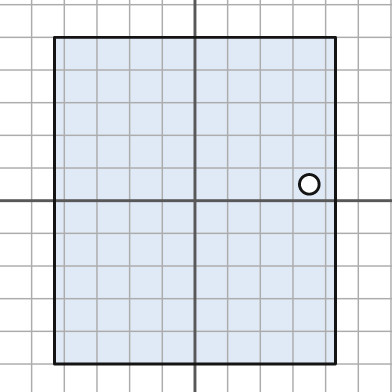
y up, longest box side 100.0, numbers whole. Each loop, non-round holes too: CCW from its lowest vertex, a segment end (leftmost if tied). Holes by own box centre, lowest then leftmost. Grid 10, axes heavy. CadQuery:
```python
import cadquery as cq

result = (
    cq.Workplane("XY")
    .moveTo(-43.0, -50.0)
    .lineTo(43.0, -50.0)
    .lineTo(43.0, 50.0)
    .lineTo(-43.0, 50.0)
    .close()
    .moveTo(35.0, 5.0)
    .circle(3.0)
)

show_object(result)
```